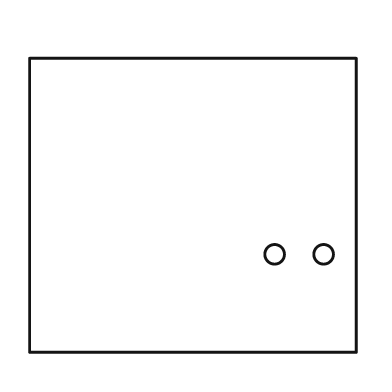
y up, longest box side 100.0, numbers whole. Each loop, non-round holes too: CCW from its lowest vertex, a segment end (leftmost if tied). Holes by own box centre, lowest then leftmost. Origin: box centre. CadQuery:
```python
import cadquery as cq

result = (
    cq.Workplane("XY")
    .moveTo(-50.0, -45.0)
    .lineTo(50.0, -45.0)
    .lineTo(50.0, 45.0)
    .lineTo(-50.0, 45.0)
    .close()
    .moveTo(25.0, -15.0)
    .circle(3.0)
    .moveTo(40.0, -15.0)
    .circle(3.0)
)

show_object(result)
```